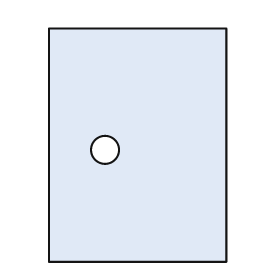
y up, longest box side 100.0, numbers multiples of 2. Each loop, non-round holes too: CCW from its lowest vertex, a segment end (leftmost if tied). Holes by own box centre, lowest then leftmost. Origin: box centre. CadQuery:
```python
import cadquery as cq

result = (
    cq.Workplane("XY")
    .moveTo(-38.0, -50.0)
    .lineTo(38.0, -50.0)
    .lineTo(38.0, 50.0)
    .lineTo(-38.0, 50.0)
    .close()
    .moveTo(-14.0, -2.0)
    .circle(6.0)
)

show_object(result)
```